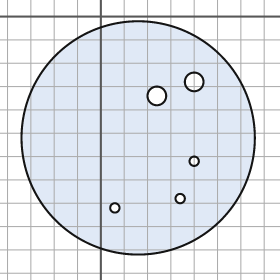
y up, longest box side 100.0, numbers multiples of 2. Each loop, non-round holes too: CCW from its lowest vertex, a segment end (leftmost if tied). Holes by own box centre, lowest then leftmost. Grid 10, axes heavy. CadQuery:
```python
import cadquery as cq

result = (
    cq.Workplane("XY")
    .moveTo(16.0, -52.0)
    .circle(50.0)
    .moveTo(6.0, -82.0)
    .circle(2.0)
    .moveTo(34.0, -78.0)
    .circle(2.0)
    .moveTo(40.0, -62.0)
    .circle(2.0)
    .moveTo(24.0, -34.0)
    .circle(4.0)
    .moveTo(40.0, -28.0)
    .circle(4.0)
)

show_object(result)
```